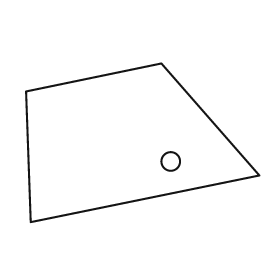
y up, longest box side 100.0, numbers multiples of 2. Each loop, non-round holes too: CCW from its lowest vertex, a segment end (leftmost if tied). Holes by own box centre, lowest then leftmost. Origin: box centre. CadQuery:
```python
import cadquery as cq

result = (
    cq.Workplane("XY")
    .moveTo(-48.0, -34.0)
    .lineTo(50.0, -14.0)
    .lineTo(8.0, 34.0)
    .lineTo(-50.0, 22.0)
    .close()
    .moveTo(12.0, -8.0)
    .circle(4.0)
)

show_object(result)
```